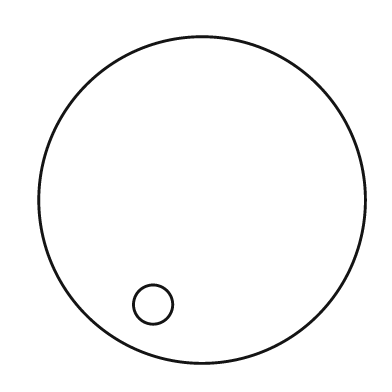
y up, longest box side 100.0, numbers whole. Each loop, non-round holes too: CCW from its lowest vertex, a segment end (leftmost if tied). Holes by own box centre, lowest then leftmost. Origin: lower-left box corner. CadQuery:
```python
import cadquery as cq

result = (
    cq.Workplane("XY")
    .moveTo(50.0, 50.0)
    .circle(50.0)
    .moveTo(35.0, 18.0)
    .circle(6.0)
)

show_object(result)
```